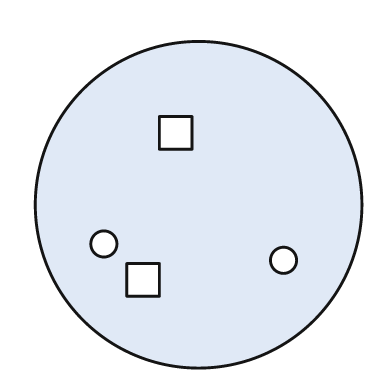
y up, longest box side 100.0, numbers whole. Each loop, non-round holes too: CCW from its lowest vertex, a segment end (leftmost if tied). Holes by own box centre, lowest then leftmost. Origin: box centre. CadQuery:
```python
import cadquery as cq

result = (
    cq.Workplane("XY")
    .moveTo(0.0, 0.0)
    .circle(50.0)
    .moveTo(-22.0, -28.0)
    .lineTo(-12.0, -28.0)
    .lineTo(-12.0, -18.0)
    .lineTo(-22.0, -18.0)
    .close()
    .moveTo(26.0, -17.0)
    .circle(4.0)
    .moveTo(-29.0, -12.0)
    .circle(4.0)
    .moveTo(-12.0, 17.0)
    .lineTo(-2.0, 17.0)
    .lineTo(-2.0, 27.0)
    .lineTo(-12.0, 27.0)
    .close()
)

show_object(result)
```